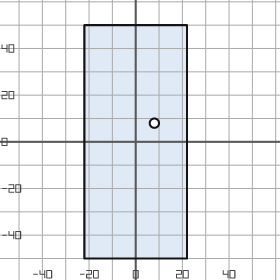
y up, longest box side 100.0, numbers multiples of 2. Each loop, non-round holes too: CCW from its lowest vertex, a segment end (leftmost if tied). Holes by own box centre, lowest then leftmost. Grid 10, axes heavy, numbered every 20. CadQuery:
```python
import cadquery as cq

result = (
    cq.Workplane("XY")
    .moveTo(-22.0, -50.0)
    .lineTo(22.0, -50.0)
    .lineTo(22.0, 50.0)
    .lineTo(-22.0, 50.0)
    .close()
    .moveTo(8.0, 8.0)
    .circle(2.0)
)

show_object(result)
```